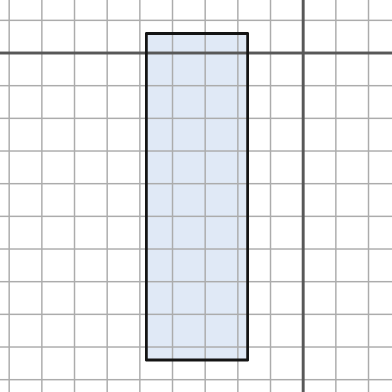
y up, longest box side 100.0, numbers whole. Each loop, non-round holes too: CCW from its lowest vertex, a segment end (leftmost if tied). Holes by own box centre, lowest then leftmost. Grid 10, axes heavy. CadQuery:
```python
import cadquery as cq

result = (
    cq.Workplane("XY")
    .moveTo(-48.0, -94.0)
    .lineTo(-17.0, -94.0)
    .lineTo(-17.0, 6.0)
    .lineTo(-48.0, 6.0)
    .close()
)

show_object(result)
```